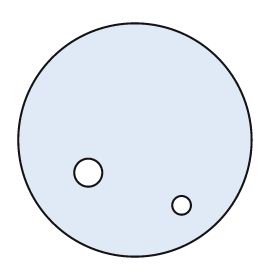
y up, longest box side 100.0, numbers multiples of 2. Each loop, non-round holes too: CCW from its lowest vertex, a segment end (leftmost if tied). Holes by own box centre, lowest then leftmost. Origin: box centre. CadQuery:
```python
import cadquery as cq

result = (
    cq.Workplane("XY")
    .moveTo(0.0, 0.0)
    .circle(50.0)
    .moveTo(20.0, -28.0)
    .circle(4.0)
    .moveTo(-20.0, -14.0)
    .circle(6.0)
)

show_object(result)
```